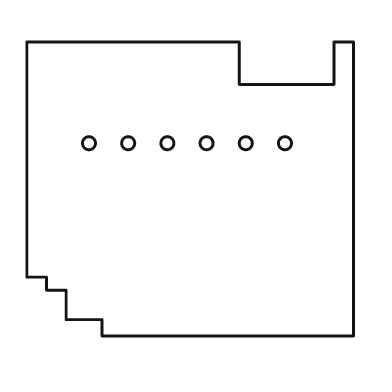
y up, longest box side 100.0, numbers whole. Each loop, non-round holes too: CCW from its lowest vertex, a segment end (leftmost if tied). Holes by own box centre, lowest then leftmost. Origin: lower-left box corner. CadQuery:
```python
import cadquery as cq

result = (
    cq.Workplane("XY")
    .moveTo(23.0, 0.0)
    .lineTo(100.0, 0.0)
    .lineTo(100.0, 90.0)
    .lineTo(94.0, 90.0)
    .lineTo(94.0, 77.0)
    .lineTo(65.0, 77.0)
    .lineTo(65.0, 90.0)
    .lineTo(0.0, 90.0)
    .lineTo(0.0, 18.0)
    .lineTo(6.0, 18.0)
    .lineTo(6.0, 14.0)
    .lineTo(12.0, 14.0)
    .lineTo(12.0, 5.0)
    .lineTo(23.0, 5.0)
    .close()
    .moveTo(19.0, 59.0)
    .circle(2.0)
    .moveTo(31.0, 59.0)
    .circle(2.0)
    .moveTo(43.0, 59.0)
    .circle(2.0)
    .moveTo(55.0, 59.0)
    .circle(2.0)
    .moveTo(67.0, 59.0)
    .circle(2.0)
    .moveTo(79.0, 59.0)
    .circle(2.0)
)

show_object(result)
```